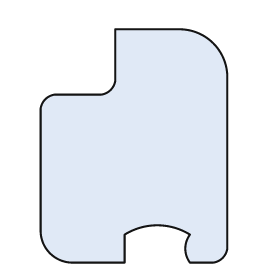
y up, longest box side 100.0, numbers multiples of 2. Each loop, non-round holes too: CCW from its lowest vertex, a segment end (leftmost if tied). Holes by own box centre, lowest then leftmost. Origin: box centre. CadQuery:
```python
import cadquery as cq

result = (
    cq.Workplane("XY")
    .moveTo(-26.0, -50.0)
    .lineTo(-4.0, -50.0)
    .lineTo(-4.0, -38.0)
    .threePointArc((10.0, -34.0), (24.0, -38.0))
    .threePointArc((22.0, -44.0), (24.0, -50.0))
    .lineTo(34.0, -50.0)
    .threePointArc((38.0, -48.0), (40.0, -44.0))
    .lineTo(40.0, 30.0)
    .threePointArc((34.0, 44.0), (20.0, 50.0))
    .lineTo(-8.0, 50.0)
    .lineTo(-8.0, 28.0)
    .threePointArc((-10.0, 24.0), (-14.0, 22.0))
    .lineTo(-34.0, 22.0)
    .threePointArc((-38.0, 20.0), (-40.0, 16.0))
    .lineTo(-40.0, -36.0)
    .threePointArc((-36.0, -46.0), (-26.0, -50.0))
    .close()
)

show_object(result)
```